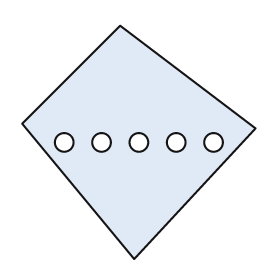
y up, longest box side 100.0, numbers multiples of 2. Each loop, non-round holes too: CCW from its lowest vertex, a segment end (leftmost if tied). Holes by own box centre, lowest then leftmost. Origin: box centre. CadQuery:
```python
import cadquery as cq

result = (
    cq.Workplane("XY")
    .moveTo(-2.0, -50.0)
    .lineTo(50.0, 6.0)
    .lineTo(-8.0, 50.0)
    .lineTo(-50.0, 8.0)
    .close()
    .moveTo(-32.0, 0.0)
    .circle(4.0)
    .moveTo(-16.0, 0.0)
    .circle(4.0)
    .moveTo(0.0, 0.0)
    .circle(4.0)
    .moveTo(16.0, 0.0)
    .circle(4.0)
    .moveTo(32.0, 0.0)
    .circle(4.0)
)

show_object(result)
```